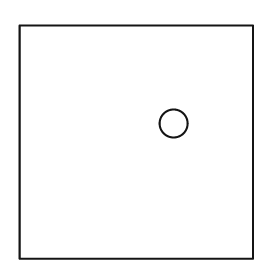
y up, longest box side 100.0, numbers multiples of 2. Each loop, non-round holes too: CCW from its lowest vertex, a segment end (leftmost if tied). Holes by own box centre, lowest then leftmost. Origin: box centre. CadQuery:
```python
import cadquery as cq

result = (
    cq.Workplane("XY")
    .moveTo(-50.0, -50.0)
    .lineTo(50.0, -50.0)
    .lineTo(50.0, 50.0)
    .lineTo(-50.0, 50.0)
    .close()
    .moveTo(16.0, 8.0)
    .circle(6.0)
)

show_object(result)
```